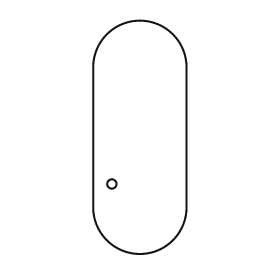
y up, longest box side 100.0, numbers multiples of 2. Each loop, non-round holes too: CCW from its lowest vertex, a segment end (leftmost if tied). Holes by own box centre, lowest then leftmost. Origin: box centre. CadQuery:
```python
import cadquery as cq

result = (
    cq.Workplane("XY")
    .moveTo(-20.0, -30.0)
    .threePointArc((0.0, -50.0), (20.0, -30.0))
    .lineTo(20.0, 30.0)
    .threePointArc((0.0, 50.0), (-20.0, 30.0))
    .close()
    .moveTo(-12.0, -20.0)
    .circle(2.0)
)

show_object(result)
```